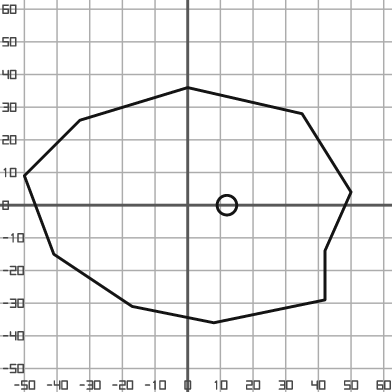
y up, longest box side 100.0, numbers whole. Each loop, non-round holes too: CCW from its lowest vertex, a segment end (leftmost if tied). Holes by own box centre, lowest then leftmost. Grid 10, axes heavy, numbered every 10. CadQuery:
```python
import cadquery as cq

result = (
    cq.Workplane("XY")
    .moveTo(8.0, -36.0)
    .lineTo(42.0, -29.0)
    .lineTo(42.0, -14.0)
    .lineTo(50.0, 4.0)
    .lineTo(35.0, 28.0)
    .lineTo(0.0, 36.0)
    .lineTo(-33.0, 26.0)
    .lineTo(-50.0, 9.0)
    .lineTo(-41.0, -15.0)
    .lineTo(-17.0, -31.0)
    .close()
    .moveTo(12.0, 0.0)
    .circle(3.0)
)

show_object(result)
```